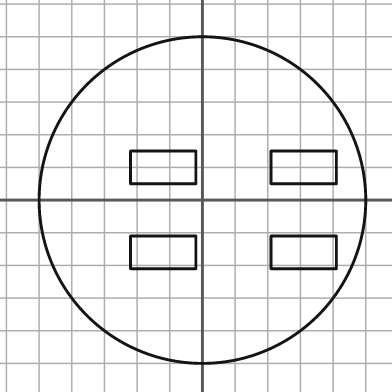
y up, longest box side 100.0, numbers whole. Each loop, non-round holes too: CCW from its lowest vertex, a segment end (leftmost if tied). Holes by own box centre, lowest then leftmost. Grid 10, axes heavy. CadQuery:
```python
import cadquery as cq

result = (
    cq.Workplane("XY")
    .moveTo(0.0, 0.0)
    .circle(50.0)
    .moveTo(-22.0, -21.0)
    .lineTo(-2.0, -21.0)
    .lineTo(-2.0, -11.0)
    .lineTo(-22.0, -11.0)
    .close()
    .moveTo(21.0, -21.0)
    .lineTo(41.0, -21.0)
    .lineTo(41.0, -11.0)
    .lineTo(21.0, -11.0)
    .close()
    .moveTo(-22.0, 5.0)
    .lineTo(-2.0, 5.0)
    .lineTo(-2.0, 15.0)
    .lineTo(-22.0, 15.0)
    .close()
    .moveTo(21.0, 5.0)
    .lineTo(41.0, 5.0)
    .lineTo(41.0, 15.0)
    .lineTo(21.0, 15.0)
    .close()
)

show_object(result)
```